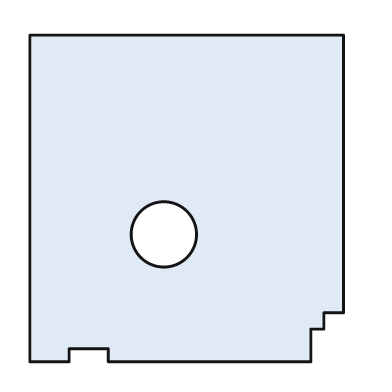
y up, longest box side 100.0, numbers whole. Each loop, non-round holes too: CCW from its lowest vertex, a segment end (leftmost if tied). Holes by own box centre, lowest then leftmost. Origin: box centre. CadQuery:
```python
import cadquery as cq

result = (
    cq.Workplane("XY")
    .moveTo(-48.0, -50.0)
    .lineTo(-36.0, -50.0)
    .lineTo(-36.0, -46.0)
    .lineTo(-24.0, -46.0)
    .lineTo(-24.0, -50.0)
    .lineTo(38.0, -50.0)
    .lineTo(38.0, -40.0)
    .lineTo(42.0, -40.0)
    .lineTo(42.0, -35.0)
    .lineTo(48.0, -35.0)
    .lineTo(48.0, 50.0)
    .lineTo(-48.0, 50.0)
    .close()
    .moveTo(-7.0, -11.0)
    .circle(10.0)
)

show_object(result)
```